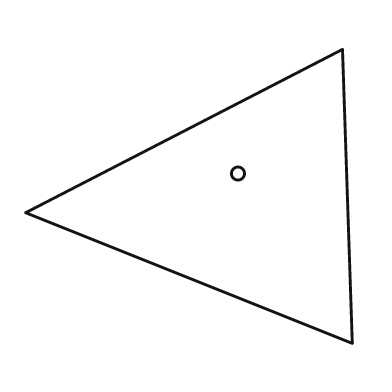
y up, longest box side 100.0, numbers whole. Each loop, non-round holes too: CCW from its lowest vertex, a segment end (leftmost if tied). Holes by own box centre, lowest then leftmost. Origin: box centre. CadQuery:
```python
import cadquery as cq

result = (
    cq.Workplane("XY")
    .moveTo(50.0, -45.0)
    .lineTo(47.0, 45.0)
    .lineTo(-50.0, -5.0)
    .close()
    .moveTo(15.0, 7.0)
    .circle(2.0)
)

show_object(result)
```